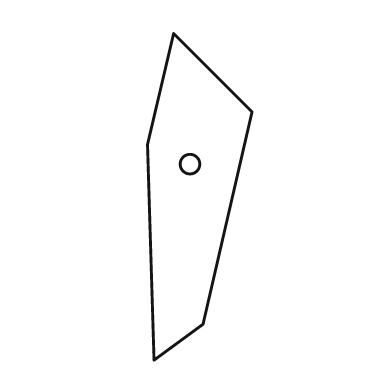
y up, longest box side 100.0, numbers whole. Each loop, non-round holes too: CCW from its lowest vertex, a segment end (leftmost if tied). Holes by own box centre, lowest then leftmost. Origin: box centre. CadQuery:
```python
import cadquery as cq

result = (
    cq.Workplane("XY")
    .moveTo(-14.0, -50.0)
    .lineTo(1.0, -39.0)
    .lineTo(16.0, 26.0)
    .lineTo(-8.0, 50.0)
    .lineTo(-16.0, 16.0)
    .close()
    .moveTo(-3.0, 10.0)
    .circle(3.0)
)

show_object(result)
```